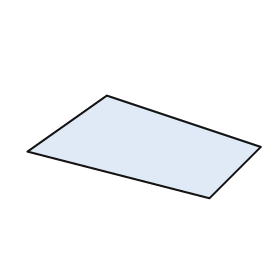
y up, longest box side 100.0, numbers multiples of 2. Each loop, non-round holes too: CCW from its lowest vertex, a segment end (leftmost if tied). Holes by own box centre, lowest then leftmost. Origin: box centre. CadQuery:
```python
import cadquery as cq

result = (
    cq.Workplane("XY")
    .moveTo(28.0, -22.0)
    .lineTo(50.0, 0.0)
    .lineTo(-16.0, 22.0)
    .lineTo(-50.0, -2.0)
    .close()
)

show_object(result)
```